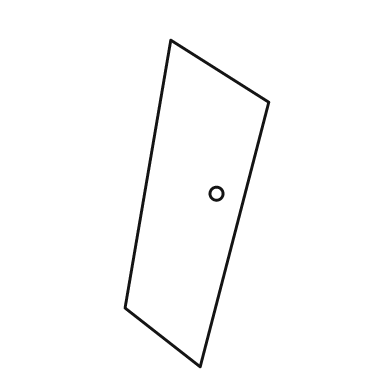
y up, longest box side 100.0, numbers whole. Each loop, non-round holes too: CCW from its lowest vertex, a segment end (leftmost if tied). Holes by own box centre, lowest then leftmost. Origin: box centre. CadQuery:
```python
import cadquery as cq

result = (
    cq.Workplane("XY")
    .moveTo(1.0, -50.0)
    .lineTo(22.0, 31.0)
    .lineTo(-8.0, 50.0)
    .lineTo(-22.0, -32.0)
    .close()
    .moveTo(6.0, 3.0)
    .circle(2.0)
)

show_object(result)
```